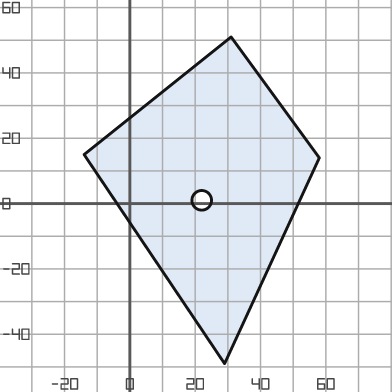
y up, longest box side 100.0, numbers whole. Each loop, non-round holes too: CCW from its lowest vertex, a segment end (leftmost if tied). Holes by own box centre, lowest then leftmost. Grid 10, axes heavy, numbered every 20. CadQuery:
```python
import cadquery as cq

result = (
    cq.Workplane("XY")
    .moveTo(29.0, -49.0)
    .lineTo(58.0, 14.0)
    .lineTo(31.0, 51.0)
    .lineTo(-14.0, 15.0)
    .close()
    .moveTo(22.0, 1.0)
    .circle(3.0)
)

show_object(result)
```